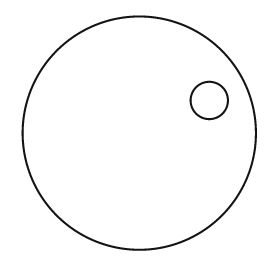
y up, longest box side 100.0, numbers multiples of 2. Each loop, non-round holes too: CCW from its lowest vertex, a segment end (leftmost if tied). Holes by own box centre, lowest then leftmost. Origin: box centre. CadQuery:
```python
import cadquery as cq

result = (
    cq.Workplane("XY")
    .moveTo(0.0, 0.0)
    .circle(50.0)
    .moveTo(30.0, 14.0)
    .circle(8.0)
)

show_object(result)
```